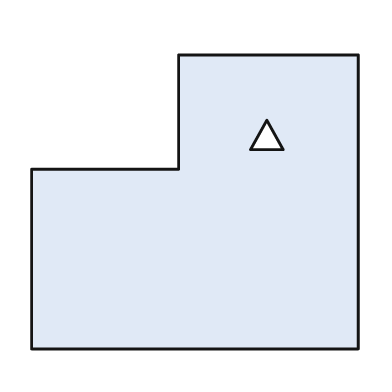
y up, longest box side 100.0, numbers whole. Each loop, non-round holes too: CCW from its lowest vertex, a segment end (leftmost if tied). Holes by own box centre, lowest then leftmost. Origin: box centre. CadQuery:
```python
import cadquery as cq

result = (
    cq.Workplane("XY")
    .moveTo(-50.0, -45.0)
    .lineTo(50.0, -45.0)
    .lineTo(50.0, 45.0)
    .lineTo(-5.0, 45.0)
    .lineTo(-5.0, 10.0)
    .lineTo(-50.0, 10.0)
    .close()
    .moveTo(17.0, 16.0)
    .lineTo(27.0, 16.0)
    .lineTo(22.0, 25.0)
    .close()
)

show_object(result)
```